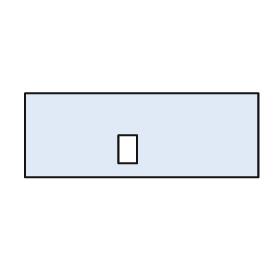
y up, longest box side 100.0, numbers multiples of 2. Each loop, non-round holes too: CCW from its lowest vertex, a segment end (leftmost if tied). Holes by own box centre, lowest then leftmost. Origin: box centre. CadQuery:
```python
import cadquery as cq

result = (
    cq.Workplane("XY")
    .moveTo(-50.0, -18.0)
    .lineTo(50.0, -18.0)
    .lineTo(50.0, 18.0)
    .lineTo(-50.0, 18.0)
    .close()
    .moveTo(-10.0, -12.0)
    .lineTo(-2.0, -12.0)
    .lineTo(-2.0, 0.0)
    .lineTo(-10.0, 0.0)
    .close()
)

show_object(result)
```